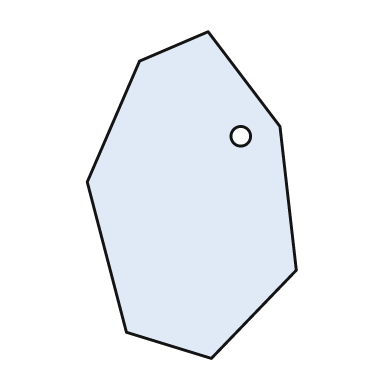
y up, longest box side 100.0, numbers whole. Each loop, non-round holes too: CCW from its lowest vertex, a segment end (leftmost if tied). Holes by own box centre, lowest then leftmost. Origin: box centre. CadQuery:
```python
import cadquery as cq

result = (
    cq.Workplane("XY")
    .moveTo(6.0, -50.0)
    .lineTo(32.0, -23.0)
    .lineTo(27.0, 21.0)
    .lineTo(5.0, 50.0)
    .lineTo(-16.0, 41.0)
    .lineTo(-32.0, 4.0)
    .lineTo(-20.0, -42.0)
    .close()
    .moveTo(15.0, 18.0)
    .circle(3.0)
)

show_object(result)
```